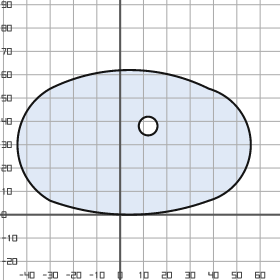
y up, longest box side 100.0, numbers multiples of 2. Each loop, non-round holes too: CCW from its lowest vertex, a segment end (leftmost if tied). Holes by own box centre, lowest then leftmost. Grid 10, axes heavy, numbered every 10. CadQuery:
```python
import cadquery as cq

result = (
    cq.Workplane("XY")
    .moveTo(-30.0, 6.0)
    .threePointArc((4.0, 0.0), (38.0, 6.0))
    .threePointArc((56.0, 30.0), (38.0, 54.0))
    .threePointArc((4.0, 62.0), (-30.0, 54.0))
    .threePointArc((-44.0, 30.0), (-30.0, 6.0))
    .close()
    .moveTo(12.0, 38.0)
    .circle(4.0)
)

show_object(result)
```